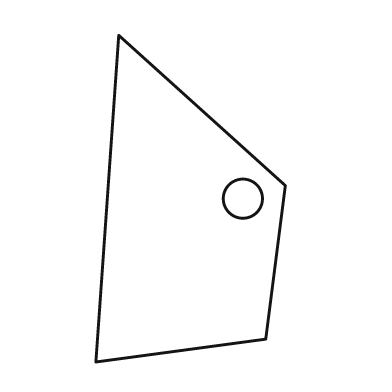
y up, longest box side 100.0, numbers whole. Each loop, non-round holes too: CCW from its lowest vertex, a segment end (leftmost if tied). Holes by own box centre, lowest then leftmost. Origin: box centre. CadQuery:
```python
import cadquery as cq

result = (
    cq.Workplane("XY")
    .moveTo(-29.0, -50.0)
    .lineTo(23.0, -43.0)
    .lineTo(29.0, 4.0)
    .lineTo(-22.0, 50.0)
    .close()
    .moveTo(16.0, 0.0)
    .circle(6.0)
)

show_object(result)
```